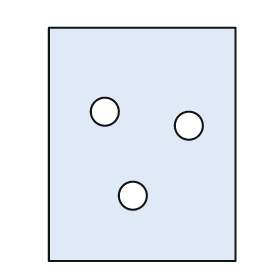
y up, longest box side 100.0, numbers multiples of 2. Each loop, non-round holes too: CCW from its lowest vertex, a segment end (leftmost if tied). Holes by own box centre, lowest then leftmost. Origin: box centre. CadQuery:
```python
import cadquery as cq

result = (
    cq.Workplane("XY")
    .moveTo(-40.0, -50.0)
    .lineTo(40.0, -50.0)
    .lineTo(40.0, 50.0)
    .lineTo(-40.0, 50.0)
    .close()
    .moveTo(-4.0, -22.0)
    .circle(6.0)
    .moveTo(20.0, 8.0)
    .circle(6.0)
    .moveTo(-16.0, 14.0)
    .circle(6.0)
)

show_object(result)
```